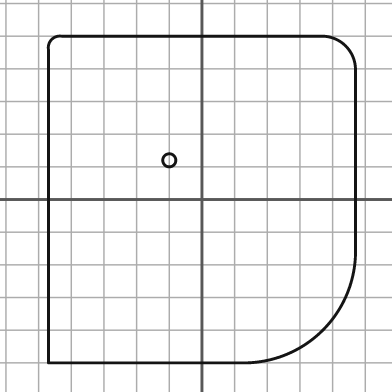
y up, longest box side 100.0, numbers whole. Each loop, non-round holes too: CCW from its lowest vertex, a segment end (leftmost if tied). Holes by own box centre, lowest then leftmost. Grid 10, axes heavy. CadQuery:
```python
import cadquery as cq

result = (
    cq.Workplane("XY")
    .moveTo(-47.0, -50.0)
    .lineTo(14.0, -50.0)
    .threePointArc((37.0, -40.0), (47.0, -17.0))
    .lineTo(47.0, 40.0)
    .threePointArc((44.0, 47.0), (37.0, 50.0))
    .lineTo(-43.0, 50.0)
    .threePointArc((-46.0, 49.0), (-47.0, 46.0))
    .close()
    .moveTo(-10.0, 12.0)
    .circle(2.0)
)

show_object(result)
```